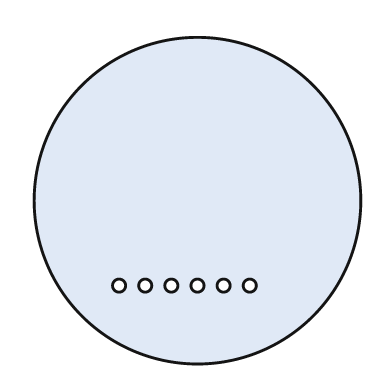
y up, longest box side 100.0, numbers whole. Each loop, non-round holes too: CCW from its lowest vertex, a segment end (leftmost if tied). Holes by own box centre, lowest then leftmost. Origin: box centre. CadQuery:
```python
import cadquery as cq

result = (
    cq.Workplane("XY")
    .moveTo(0.0, 0.0)
    .circle(50.0)
    .moveTo(-24.0, -26.0)
    .circle(2.0)
    .moveTo(-16.0, -26.0)
    .circle(2.0)
    .moveTo(-8.0, -26.0)
    .circle(2.0)
    .moveTo(0.0, -26.0)
    .circle(2.0)
    .moveTo(8.0, -26.0)
    .circle(2.0)
    .moveTo(16.0, -26.0)
    .circle(2.0)
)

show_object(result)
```